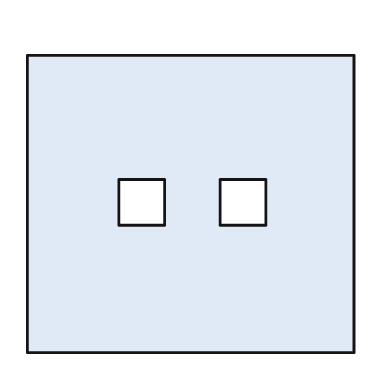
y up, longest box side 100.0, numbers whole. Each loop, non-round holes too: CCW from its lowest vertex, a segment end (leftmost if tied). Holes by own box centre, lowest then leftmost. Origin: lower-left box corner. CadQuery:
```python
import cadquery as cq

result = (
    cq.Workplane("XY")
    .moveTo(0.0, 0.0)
    .lineTo(100.0, 0.0)
    .lineTo(100.0, 91.0)
    .lineTo(0.0, 91.0)
    .close()
    .moveTo(28.0, 39.0)
    .lineTo(42.0, 39.0)
    .lineTo(42.0, 53.0)
    .lineTo(28.0, 53.0)
    .close()
    .moveTo(59.0, 39.0)
    .lineTo(73.0, 39.0)
    .lineTo(73.0, 53.0)
    .lineTo(59.0, 53.0)
    .close()
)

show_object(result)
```